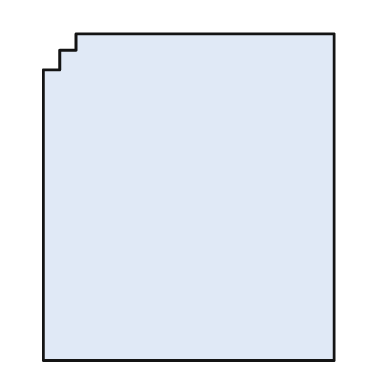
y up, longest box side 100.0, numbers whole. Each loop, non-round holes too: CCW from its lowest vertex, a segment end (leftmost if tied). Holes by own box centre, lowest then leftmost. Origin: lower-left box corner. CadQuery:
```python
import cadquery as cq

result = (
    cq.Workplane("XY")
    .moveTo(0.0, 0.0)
    .lineTo(89.0, 0.0)
    .lineTo(89.0, 100.0)
    .lineTo(10.0, 100.0)
    .lineTo(10.0, 95.0)
    .lineTo(5.0, 95.0)
    .lineTo(5.0, 89.0)
    .lineTo(0.0, 89.0)
    .close()
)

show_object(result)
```